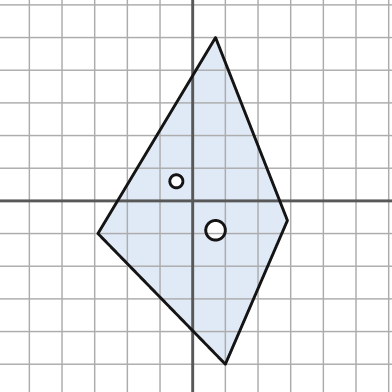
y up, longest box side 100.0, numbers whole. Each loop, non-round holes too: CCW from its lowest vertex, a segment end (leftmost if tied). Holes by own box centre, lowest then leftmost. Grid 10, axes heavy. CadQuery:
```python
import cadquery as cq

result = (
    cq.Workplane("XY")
    .moveTo(10.0, -50.0)
    .lineTo(29.0, -6.0)
    .lineTo(7.0, 50.0)
    .lineTo(-29.0, -10.0)
    .close()
    .moveTo(7.0, -9.0)
    .circle(3.0)
    .moveTo(-5.0, 6.0)
    .circle(2.0)
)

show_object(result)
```